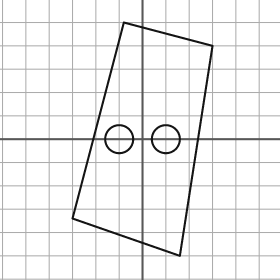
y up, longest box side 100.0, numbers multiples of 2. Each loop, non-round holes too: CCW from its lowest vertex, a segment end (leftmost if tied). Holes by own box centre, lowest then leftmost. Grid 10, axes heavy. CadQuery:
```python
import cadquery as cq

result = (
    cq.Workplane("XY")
    .moveTo(16.0, -50.0)
    .lineTo(30.0, 40.0)
    .lineTo(-8.0, 50.0)
    .lineTo(-30.0, -34.0)
    .close()
    .moveTo(-10.0, 0.0)
    .circle(6.0)
    .moveTo(10.0, 0.0)
    .circle(6.0)
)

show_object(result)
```